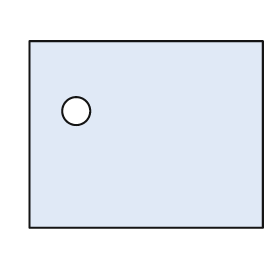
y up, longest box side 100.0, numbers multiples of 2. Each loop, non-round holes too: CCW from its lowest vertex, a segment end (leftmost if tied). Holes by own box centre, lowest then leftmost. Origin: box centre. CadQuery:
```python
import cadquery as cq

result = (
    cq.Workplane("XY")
    .moveTo(-50.0, -40.0)
    .lineTo(50.0, -40.0)
    .lineTo(50.0, 40.0)
    .lineTo(-50.0, 40.0)
    .close()
    .moveTo(-30.0, 10.0)
    .circle(6.0)
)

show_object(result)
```